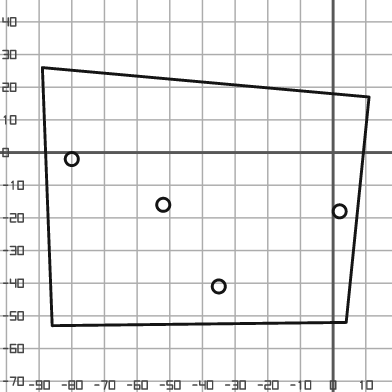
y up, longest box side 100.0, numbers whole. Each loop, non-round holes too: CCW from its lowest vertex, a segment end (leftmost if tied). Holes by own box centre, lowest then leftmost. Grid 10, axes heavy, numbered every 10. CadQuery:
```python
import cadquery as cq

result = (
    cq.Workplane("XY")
    .moveTo(-86.0, -53.0)
    .lineTo(4.0, -52.0)
    .lineTo(11.0, 17.0)
    .lineTo(-89.0, 26.0)
    .close()
    .moveTo(-35.0, -41.0)
    .circle(2.0)
    .moveTo(2.0, -18.0)
    .circle(2.0)
    .moveTo(-52.0, -16.0)
    .circle(2.0)
    .moveTo(-80.0, -2.0)
    .circle(2.0)
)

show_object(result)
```